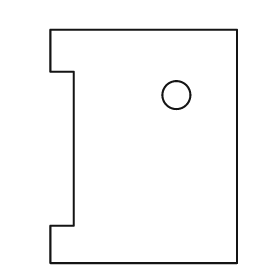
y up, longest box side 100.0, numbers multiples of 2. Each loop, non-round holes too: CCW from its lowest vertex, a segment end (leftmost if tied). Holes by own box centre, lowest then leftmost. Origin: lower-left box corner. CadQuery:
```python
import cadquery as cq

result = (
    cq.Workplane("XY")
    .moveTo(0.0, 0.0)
    .lineTo(80.0, 0.0)
    .lineTo(80.0, 100.0)
    .lineTo(0.0, 100.0)
    .lineTo(0.0, 82.0)
    .lineTo(10.0, 82.0)
    .lineTo(10.0, 16.0)
    .lineTo(0.0, 16.0)
    .close()
    .moveTo(54.0, 72.0)
    .circle(6.0)
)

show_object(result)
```